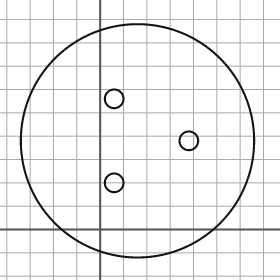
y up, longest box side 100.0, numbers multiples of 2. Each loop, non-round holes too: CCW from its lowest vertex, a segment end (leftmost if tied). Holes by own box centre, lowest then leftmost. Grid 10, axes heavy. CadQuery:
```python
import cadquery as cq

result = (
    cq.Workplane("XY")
    .moveTo(16.0, 38.0)
    .circle(50.0)
    .moveTo(6.0, 20.0)
    .circle(4.0)
    .moveTo(38.0, 38.0)
    .circle(4.0)
    .moveTo(6.0, 56.0)
    .circle(4.0)
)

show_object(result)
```